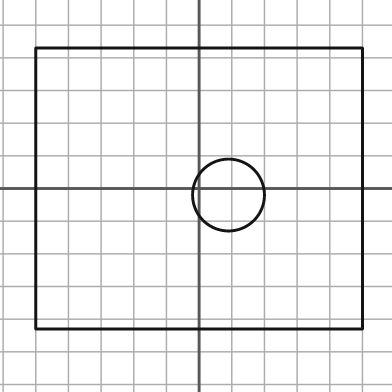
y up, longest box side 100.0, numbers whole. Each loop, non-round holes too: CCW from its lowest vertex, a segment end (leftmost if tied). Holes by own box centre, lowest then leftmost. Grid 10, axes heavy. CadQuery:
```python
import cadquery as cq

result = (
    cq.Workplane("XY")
    .moveTo(-50.0, -43.0)
    .lineTo(50.0, -43.0)
    .lineTo(50.0, 43.0)
    .lineTo(-50.0, 43.0)
    .close()
    .moveTo(9.0, -2.0)
    .circle(11.0)
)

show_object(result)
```